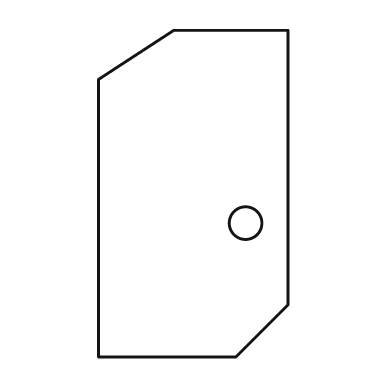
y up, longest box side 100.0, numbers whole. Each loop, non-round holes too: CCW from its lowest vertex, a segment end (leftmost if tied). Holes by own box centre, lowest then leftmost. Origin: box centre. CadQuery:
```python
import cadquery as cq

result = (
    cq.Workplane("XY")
    .moveTo(-29.0, -50.0)
    .lineTo(13.0, -50.0)
    .lineTo(29.0, -34.0)
    .lineTo(29.0, 50.0)
    .lineTo(-6.0, 50.0)
    .lineTo(-29.0, 35.0)
    .close()
    .moveTo(16.0, -9.0)
    .circle(5.0)
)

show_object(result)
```